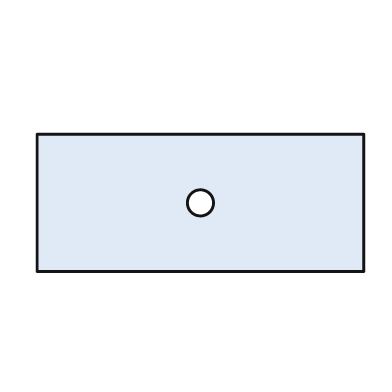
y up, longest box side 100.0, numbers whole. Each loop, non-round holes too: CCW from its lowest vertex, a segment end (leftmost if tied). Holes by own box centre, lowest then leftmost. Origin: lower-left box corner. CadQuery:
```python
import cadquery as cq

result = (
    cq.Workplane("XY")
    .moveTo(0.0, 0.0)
    .lineTo(100.0, 0.0)
    .lineTo(100.0, 42.0)
    .lineTo(0.0, 42.0)
    .close()
    .moveTo(50.0, 21.0)
    .circle(4.0)
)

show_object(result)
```